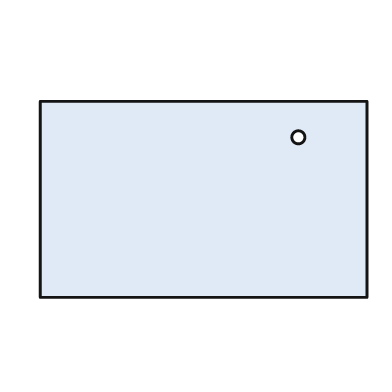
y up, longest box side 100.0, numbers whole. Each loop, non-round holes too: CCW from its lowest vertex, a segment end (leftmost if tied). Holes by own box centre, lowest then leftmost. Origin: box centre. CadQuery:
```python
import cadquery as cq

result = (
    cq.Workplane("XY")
    .moveTo(-50.0, -30.0)
    .lineTo(50.0, -30.0)
    .lineTo(50.0, 30.0)
    .lineTo(-50.0, 30.0)
    .close()
    .moveTo(29.0, 19.0)
    .circle(2.0)
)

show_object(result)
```